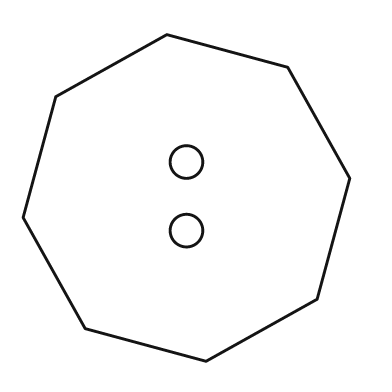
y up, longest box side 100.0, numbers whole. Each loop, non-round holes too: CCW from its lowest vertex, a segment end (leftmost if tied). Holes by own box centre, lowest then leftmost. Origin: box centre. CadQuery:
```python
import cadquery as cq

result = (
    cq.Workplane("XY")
    .moveTo(6.0, -50.0)
    .lineTo(40.0, -31.0)
    .lineTo(50.0, 6.0)
    .lineTo(31.0, 40.0)
    .lineTo(-6.0, 50.0)
    .lineTo(-40.0, 31.0)
    .lineTo(-50.0, -6.0)
    .lineTo(-31.0, -40.0)
    .close()
    .moveTo(0.0, -10.0)
    .circle(5.0)
    .moveTo(0.0, 11.0)
    .circle(5.0)
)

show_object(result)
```